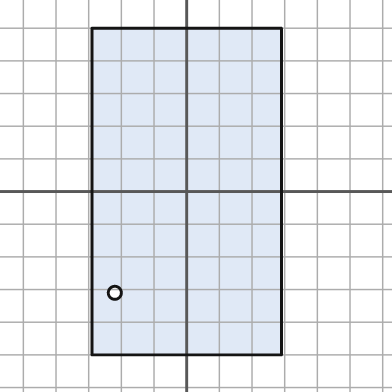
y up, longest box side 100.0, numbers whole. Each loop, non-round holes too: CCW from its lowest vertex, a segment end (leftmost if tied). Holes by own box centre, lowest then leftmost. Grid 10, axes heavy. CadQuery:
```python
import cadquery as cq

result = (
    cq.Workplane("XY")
    .moveTo(-29.0, -50.0)
    .lineTo(29.0, -50.0)
    .lineTo(29.0, 50.0)
    .lineTo(-29.0, 50.0)
    .close()
    .moveTo(-22.0, -31.0)
    .circle(2.0)
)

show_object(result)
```